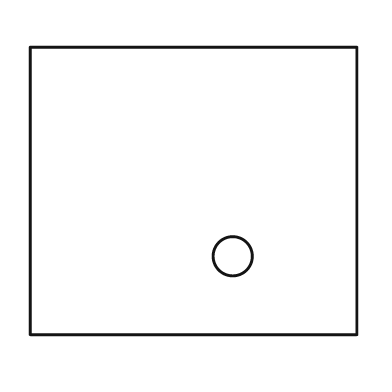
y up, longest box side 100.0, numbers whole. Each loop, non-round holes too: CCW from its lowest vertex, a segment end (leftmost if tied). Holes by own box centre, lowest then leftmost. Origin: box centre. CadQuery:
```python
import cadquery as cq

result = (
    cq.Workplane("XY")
    .moveTo(-50.0, -44.0)
    .lineTo(50.0, -44.0)
    .lineTo(50.0, 44.0)
    .lineTo(-50.0, 44.0)
    .close()
    .moveTo(12.0, -20.0)
    .circle(6.0)
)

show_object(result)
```